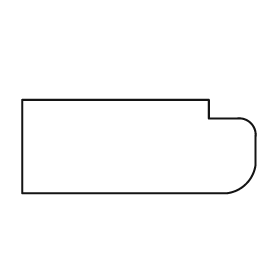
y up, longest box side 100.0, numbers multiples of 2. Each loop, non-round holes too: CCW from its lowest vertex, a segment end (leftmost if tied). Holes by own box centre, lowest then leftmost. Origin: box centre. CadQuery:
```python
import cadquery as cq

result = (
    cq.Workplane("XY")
    .moveTo(-50.0, -20.0)
    .lineTo(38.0, -20.0)
    .threePointArc((46.0, -16.0), (50.0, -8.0))
    .lineTo(50.0, 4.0)
    .threePointArc((48.0, 10.0), (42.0, 12.0))
    .lineTo(30.0, 12.0)
    .lineTo(30.0, 20.0)
    .lineTo(-50.0, 20.0)
    .close()
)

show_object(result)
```